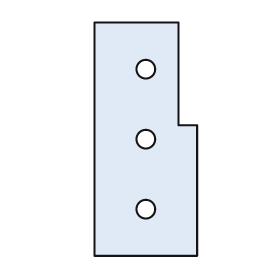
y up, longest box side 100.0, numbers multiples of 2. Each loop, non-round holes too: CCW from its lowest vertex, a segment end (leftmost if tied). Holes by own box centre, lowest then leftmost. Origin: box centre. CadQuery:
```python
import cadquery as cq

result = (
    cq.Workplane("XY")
    .moveTo(-22.0, -50.0)
    .lineTo(22.0, -50.0)
    .lineTo(22.0, 6.0)
    .lineTo(14.0, 6.0)
    .lineTo(14.0, 50.0)
    .lineTo(-22.0, 50.0)
    .close()
    .moveTo(0.0, -30.0)
    .circle(4.0)
    .moveTo(0.0, 0.0)
    .circle(4.0)
    .moveTo(0.0, 30.0)
    .circle(4.0)
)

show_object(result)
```